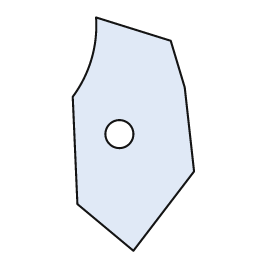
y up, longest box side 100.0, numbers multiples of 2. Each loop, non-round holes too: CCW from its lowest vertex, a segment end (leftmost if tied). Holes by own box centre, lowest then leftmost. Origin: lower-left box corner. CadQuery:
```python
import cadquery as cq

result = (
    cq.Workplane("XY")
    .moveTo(26.0, 0.0)
    .lineTo(52.0, 34.0)
    .lineTo(48.0, 70.0)
    .lineTo(42.0, 90.0)
    .lineTo(10.0, 100.0)
    .threePointArc((8.0, 82.0), (0.0, 66.0))
    .lineTo(2.0, 20.0)
    .close()
    .moveTo(20.0, 50.0)
    .circle(6.0)
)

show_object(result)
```